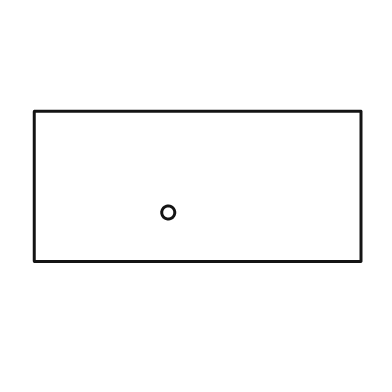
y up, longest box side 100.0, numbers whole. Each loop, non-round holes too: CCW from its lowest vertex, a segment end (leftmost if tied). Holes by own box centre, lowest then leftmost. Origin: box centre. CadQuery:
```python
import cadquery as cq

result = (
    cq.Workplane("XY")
    .moveTo(-50.0, -23.0)
    .lineTo(50.0, -23.0)
    .lineTo(50.0, 23.0)
    .lineTo(-50.0, 23.0)
    .close()
    .moveTo(-9.0, -8.0)
    .circle(2.0)
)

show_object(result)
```